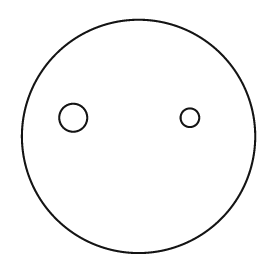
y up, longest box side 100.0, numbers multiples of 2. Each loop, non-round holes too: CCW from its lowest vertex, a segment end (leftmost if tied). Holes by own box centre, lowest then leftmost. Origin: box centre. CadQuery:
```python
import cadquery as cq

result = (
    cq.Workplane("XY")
    .moveTo(0.0, 0.0)
    .circle(50.0)
    .moveTo(-28.0, 8.0)
    .circle(6.0)
    .moveTo(22.0, 8.0)
    .circle(4.0)
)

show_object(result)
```